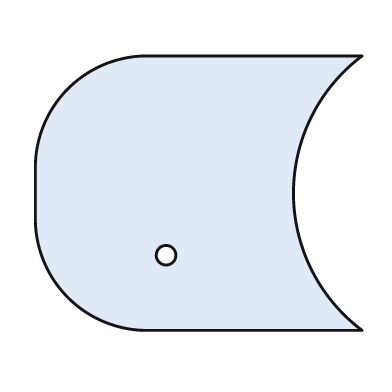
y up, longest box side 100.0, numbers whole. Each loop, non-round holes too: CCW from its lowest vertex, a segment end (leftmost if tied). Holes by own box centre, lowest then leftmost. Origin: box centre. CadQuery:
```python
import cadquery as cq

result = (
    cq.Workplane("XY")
    .moveTo(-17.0, -42.0)
    .lineTo(50.0, -42.0)
    .threePointArc((29.0, 0.0), (50.0, 42.0))
    .lineTo(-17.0, 42.0)
    .threePointArc((-40.0, 32.0), (-50.0, 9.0))
    .lineTo(-50.0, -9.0)
    .threePointArc((-40.0, -32.0), (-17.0, -42.0))
    .close()
    .moveTo(-10.0, -19.0)
    .circle(3.0)
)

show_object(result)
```